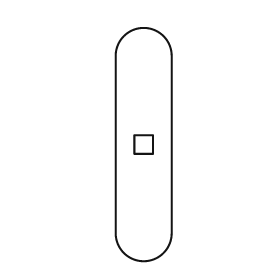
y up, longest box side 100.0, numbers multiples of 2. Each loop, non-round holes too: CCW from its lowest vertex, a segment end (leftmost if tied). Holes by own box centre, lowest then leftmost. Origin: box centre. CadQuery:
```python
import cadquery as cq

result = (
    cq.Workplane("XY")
    .moveTo(-12.0, -38.0)
    .threePointArc((0.0, -50.0), (12.0, -38.0))
    .lineTo(12.0, 38.0)
    .threePointArc((0.0, 50.0), (-12.0, 38.0))
    .close()
    .moveTo(-4.0, -4.0)
    .lineTo(4.0, -4.0)
    .lineTo(4.0, 4.0)
    .lineTo(-4.0, 4.0)
    .close()
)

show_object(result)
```